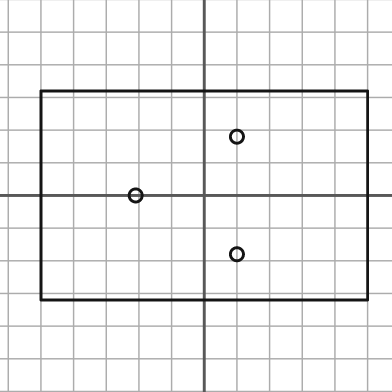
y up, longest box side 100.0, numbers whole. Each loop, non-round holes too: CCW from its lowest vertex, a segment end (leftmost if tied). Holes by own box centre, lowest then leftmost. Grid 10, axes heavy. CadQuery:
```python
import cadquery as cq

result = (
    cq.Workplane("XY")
    .moveTo(-50.0, -32.0)
    .lineTo(50.0, -32.0)
    .lineTo(50.0, 32.0)
    .lineTo(-50.0, 32.0)
    .close()
    .moveTo(10.0, -18.0)
    .circle(2.0)
    .moveTo(-21.0, 0.0)
    .circle(2.0)
    .moveTo(10.0, 18.0)
    .circle(2.0)
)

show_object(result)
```